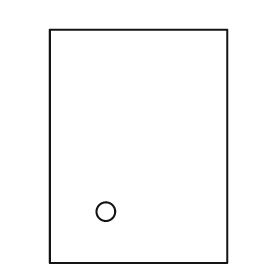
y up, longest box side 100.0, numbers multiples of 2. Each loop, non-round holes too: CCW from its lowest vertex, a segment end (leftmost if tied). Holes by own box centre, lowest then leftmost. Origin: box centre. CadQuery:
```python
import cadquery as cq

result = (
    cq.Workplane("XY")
    .moveTo(-38.0, -50.0)
    .lineTo(38.0, -50.0)
    .lineTo(38.0, 50.0)
    .lineTo(-38.0, 50.0)
    .close()
    .moveTo(-14.0, -28.0)
    .circle(4.0)
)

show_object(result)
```